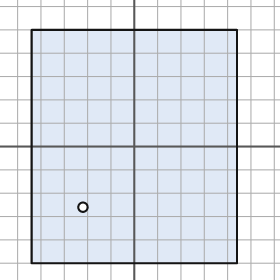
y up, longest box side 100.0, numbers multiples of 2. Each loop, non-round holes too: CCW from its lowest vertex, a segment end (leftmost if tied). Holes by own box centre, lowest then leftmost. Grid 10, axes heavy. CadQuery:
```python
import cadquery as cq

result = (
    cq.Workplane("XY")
    .moveTo(-44.0, -50.0)
    .lineTo(44.0, -50.0)
    .lineTo(44.0, 50.0)
    .lineTo(-44.0, 50.0)
    .close()
    .moveTo(-22.0, -26.0)
    .circle(2.0)
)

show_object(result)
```